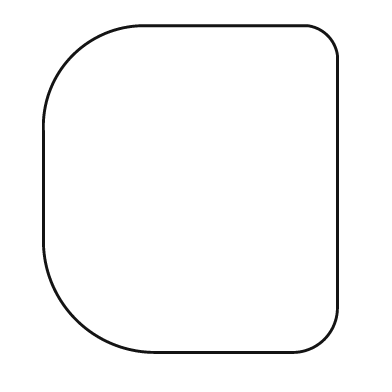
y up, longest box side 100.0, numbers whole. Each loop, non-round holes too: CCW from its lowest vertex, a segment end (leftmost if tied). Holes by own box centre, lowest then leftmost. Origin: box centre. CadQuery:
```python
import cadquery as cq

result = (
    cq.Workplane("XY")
    .moveTo(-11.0, -50.0)
    .lineTo(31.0, -50.0)
    .threePointArc((41.0, -46.0), (45.0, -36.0))
    .lineTo(45.0, 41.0)
    .threePointArc((42.0, 47.0), (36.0, 50.0))
    .lineTo(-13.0, 50.0)
    .threePointArc((-36.0, 41.0), (-45.0, 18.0))
    .lineTo(-45.0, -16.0)
    .threePointArc((-35.0, -40.0), (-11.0, -50.0))
    .close()
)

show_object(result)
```